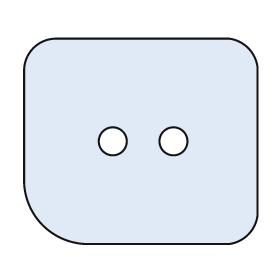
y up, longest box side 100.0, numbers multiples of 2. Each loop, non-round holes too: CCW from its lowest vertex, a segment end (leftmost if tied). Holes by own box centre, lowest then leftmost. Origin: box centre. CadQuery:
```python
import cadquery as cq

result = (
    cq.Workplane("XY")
    .moveTo(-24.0, -44.0)
    .lineTo(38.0, -44.0)
    .threePointArc((46.0, -40.0), (50.0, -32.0))
    .lineTo(50.0, 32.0)
    .threePointArc((46.0, 40.0), (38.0, 44.0))
    .lineTo(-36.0, 44.0)
    .threePointArc((-46.0, 40.0), (-50.0, 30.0))
    .lineTo(-50.0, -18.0)
    .threePointArc((-42.0, -36.0), (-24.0, -44.0))
    .close()
    .moveTo(-12.0, 0.0)
    .circle(6.0)
    .moveTo(14.0, 0.0)
    .circle(6.0)
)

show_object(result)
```